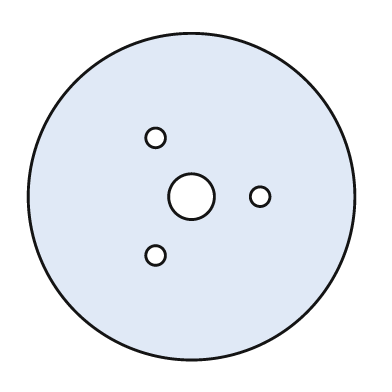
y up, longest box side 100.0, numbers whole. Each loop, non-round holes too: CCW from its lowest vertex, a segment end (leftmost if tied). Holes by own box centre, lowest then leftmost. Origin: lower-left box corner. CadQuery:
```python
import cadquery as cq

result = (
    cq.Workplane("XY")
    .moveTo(50.0, 50.0)
    .circle(50.0)
    .moveTo(39.0, 32.0)
    .circle(3.0)
    .moveTo(50.0, 50.0)
    .circle(7.0)
    .moveTo(71.0, 50.0)
    .circle(3.0)
    .moveTo(39.0, 68.0)
    .circle(3.0)
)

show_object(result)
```